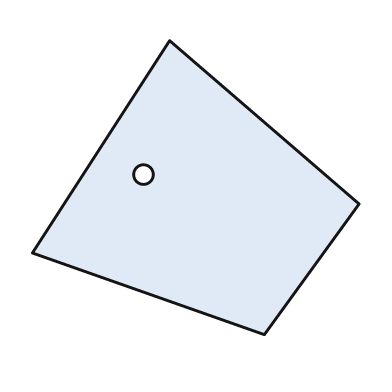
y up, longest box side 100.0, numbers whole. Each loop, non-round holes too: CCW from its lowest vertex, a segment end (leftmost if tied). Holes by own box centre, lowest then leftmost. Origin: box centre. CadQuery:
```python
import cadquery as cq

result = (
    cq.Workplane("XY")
    .moveTo(21.0, -45.0)
    .lineTo(50.0, -5.0)
    .lineTo(-8.0, 45.0)
    .lineTo(-50.0, -20.0)
    .close()
    .moveTo(-16.0, 4.0)
    .circle(3.0)
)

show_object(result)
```